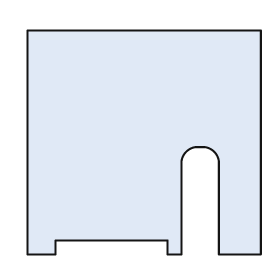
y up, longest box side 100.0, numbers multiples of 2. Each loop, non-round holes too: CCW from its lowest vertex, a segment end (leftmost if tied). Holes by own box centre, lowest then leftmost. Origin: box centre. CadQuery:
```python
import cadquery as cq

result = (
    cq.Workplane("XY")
    .moveTo(-50.0, -48.0)
    .lineTo(-38.0, -48.0)
    .lineTo(-38.0, -42.0)
    .lineTo(10.0, -42.0)
    .lineTo(10.0, -48.0)
    .lineTo(16.0, -48.0)
    .lineTo(16.0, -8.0)
    .threePointArc((18.0, -4.0), (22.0, -2.0))
    .lineTo(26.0, -2.0)
    .threePointArc((30.0, -4.0), (32.0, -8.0))
    .lineTo(32.0, -48.0)
    .lineTo(50.0, -48.0)
    .lineTo(50.0, 48.0)
    .lineTo(-50.0, 48.0)
    .close()
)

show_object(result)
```